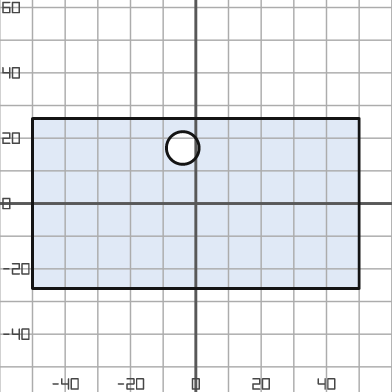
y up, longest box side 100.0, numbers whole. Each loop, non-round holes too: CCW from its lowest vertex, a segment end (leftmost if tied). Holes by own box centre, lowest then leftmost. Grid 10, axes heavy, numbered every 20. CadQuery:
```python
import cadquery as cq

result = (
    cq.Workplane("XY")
    .moveTo(-50.0, -26.0)
    .lineTo(50.0, -26.0)
    .lineTo(50.0, 26.0)
    .lineTo(-50.0, 26.0)
    .close()
    .moveTo(-4.0, 17.0)
    .circle(5.0)
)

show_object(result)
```